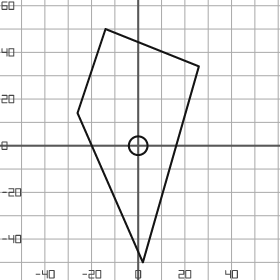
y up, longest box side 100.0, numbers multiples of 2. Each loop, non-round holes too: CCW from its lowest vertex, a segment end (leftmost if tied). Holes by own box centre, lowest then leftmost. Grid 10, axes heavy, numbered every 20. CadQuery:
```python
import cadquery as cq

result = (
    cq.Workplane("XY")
    .moveTo(2.0, -50.0)
    .lineTo(26.0, 34.0)
    .lineTo(-14.0, 50.0)
    .lineTo(-26.0, 14.0)
    .close()
    .moveTo(0.0, 0.0)
    .circle(4.0)
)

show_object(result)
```